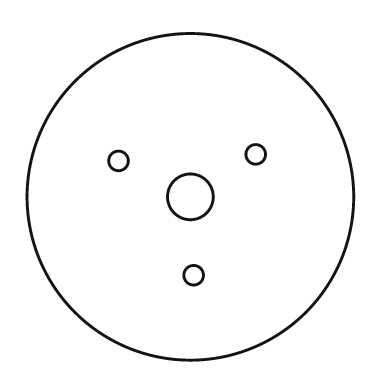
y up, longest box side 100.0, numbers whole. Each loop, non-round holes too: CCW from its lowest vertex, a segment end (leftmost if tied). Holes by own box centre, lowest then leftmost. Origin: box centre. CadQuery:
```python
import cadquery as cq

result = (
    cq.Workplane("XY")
    .moveTo(0.0, 0.0)
    .circle(50.0)
    .moveTo(1.0, -24.0)
    .circle(3.0)
    .moveTo(0.0, 0.0)
    .circle(7.0)
    .moveTo(-22.0, 11.0)
    .circle(3.0)
    .moveTo(20.0, 13.0)
    .circle(3.0)
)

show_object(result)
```